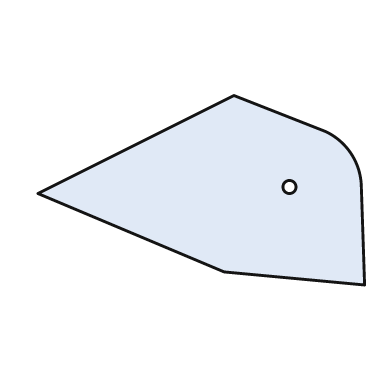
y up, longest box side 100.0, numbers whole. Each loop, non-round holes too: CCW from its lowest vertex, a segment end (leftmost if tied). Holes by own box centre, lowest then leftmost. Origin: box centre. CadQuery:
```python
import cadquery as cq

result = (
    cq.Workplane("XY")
    .moveTo(50.0, -29.0)
    .lineTo(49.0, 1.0)
    .threePointArc((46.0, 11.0), (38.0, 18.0))
    .lineTo(10.0, 29.0)
    .lineTo(-50.0, -1.0)
    .lineTo(7.0, -25.0)
    .close()
    .moveTo(27.0, 1.0)
    .circle(2.0)
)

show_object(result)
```